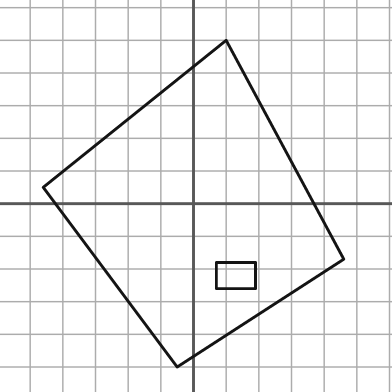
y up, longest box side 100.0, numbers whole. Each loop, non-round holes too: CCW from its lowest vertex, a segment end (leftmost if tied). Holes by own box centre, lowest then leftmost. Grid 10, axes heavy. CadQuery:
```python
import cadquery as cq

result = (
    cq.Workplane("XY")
    .moveTo(-5.0, -50.0)
    .lineTo(46.0, -17.0)
    .lineTo(10.0, 50.0)
    .lineTo(-46.0, 5.0)
    .close()
    .moveTo(7.0, -26.0)
    .lineTo(19.0, -26.0)
    .lineTo(19.0, -18.0)
    .lineTo(7.0, -18.0)
    .close()
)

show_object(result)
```